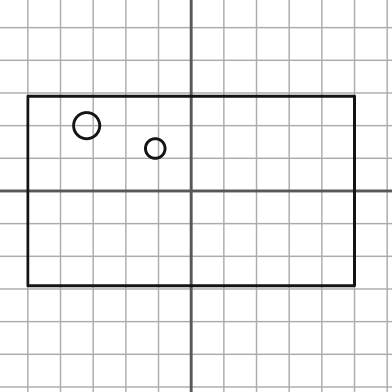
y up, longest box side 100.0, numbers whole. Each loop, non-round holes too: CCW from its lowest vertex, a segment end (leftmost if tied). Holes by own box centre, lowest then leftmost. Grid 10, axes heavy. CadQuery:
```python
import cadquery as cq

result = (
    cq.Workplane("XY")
    .moveTo(-50.0, -29.0)
    .lineTo(50.0, -29.0)
    .lineTo(50.0, 29.0)
    .lineTo(-50.0, 29.0)
    .close()
    .moveTo(-11.0, 13.0)
    .circle(3.0)
    .moveTo(-32.0, 20.0)
    .circle(4.0)
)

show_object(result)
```